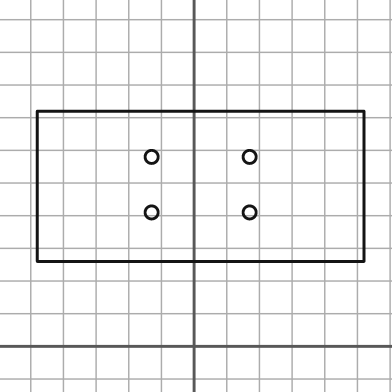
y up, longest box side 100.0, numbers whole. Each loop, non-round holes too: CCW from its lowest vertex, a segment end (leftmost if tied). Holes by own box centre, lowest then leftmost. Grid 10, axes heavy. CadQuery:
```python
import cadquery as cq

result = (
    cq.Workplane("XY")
    .moveTo(-48.0, 26.0)
    .lineTo(52.0, 26.0)
    .lineTo(52.0, 72.0)
    .lineTo(-48.0, 72.0)
    .close()
    .moveTo(-13.0, 41.0)
    .circle(2.0)
    .moveTo(17.0, 41.0)
    .circle(2.0)
    .moveTo(-13.0, 58.0)
    .circle(2.0)
    .moveTo(17.0, 58.0)
    .circle(2.0)
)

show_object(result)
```